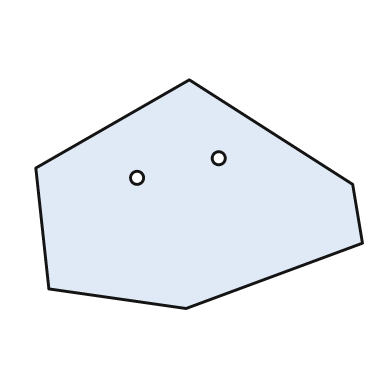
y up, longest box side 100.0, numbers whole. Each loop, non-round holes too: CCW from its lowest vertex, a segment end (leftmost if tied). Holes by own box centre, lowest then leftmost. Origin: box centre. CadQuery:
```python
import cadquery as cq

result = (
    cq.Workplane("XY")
    .moveTo(-4.0, -35.0)
    .lineTo(50.0, -15.0)
    .lineTo(47.0, 3.0)
    .lineTo(-3.0, 35.0)
    .lineTo(-50.0, 8.0)
    .lineTo(-46.0, -29.0)
    .close()
    .moveTo(-19.0, 5.0)
    .circle(2.0)
    .moveTo(6.0, 11.0)
    .circle(2.0)
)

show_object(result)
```